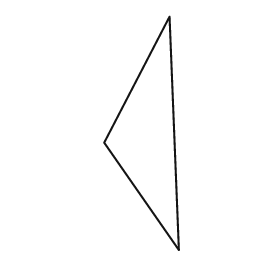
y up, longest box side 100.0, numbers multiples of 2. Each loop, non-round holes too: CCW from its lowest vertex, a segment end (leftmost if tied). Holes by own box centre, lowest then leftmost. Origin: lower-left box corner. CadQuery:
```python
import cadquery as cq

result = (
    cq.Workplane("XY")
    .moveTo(32.0, 0.0)
    .lineTo(28.0, 100.0)
    .lineTo(0.0, 46.0)
    .close()
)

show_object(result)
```